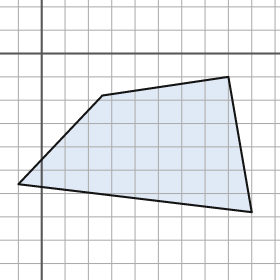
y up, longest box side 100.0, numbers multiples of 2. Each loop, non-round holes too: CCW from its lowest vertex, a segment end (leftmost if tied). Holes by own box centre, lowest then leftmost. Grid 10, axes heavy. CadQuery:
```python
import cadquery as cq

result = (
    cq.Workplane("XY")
    .moveTo(90.0, -68.0)
    .lineTo(80.0, -10.0)
    .lineTo(26.0, -18.0)
    .lineTo(-10.0, -56.0)
    .close()
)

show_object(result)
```